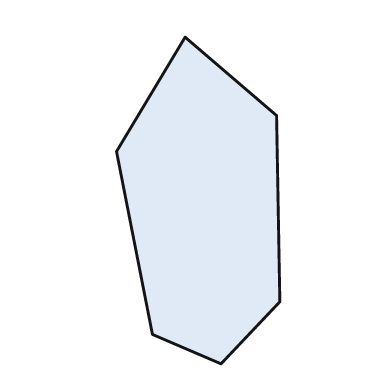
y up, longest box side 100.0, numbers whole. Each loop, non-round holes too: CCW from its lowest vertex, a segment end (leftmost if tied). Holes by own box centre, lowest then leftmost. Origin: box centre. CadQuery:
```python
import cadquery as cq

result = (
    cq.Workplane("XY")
    .moveTo(7.0, -50.0)
    .lineTo(25.0, -31.0)
    .lineTo(24.0, 26.0)
    .lineTo(-4.0, 50.0)
    .lineTo(-25.0, 15.0)
    .lineTo(-14.0, -41.0)
    .close()
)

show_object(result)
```